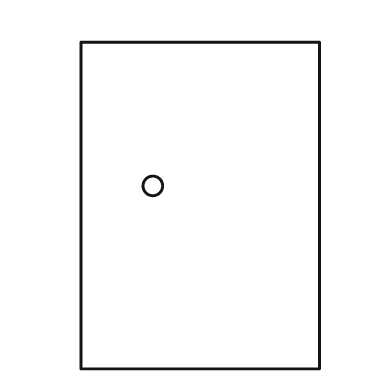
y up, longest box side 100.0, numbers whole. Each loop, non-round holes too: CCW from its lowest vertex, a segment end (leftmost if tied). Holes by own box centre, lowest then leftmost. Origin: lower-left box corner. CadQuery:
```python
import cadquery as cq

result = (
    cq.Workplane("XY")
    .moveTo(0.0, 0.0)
    .lineTo(73.0, 0.0)
    .lineTo(73.0, 100.0)
    .lineTo(0.0, 100.0)
    .close()
    .moveTo(22.0, 56.0)
    .circle(3.0)
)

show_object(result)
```